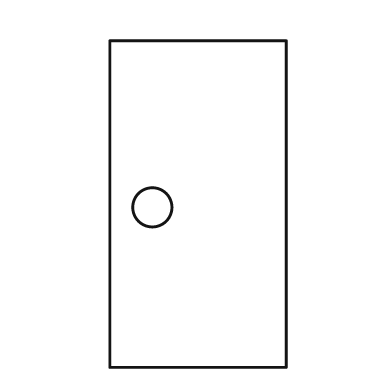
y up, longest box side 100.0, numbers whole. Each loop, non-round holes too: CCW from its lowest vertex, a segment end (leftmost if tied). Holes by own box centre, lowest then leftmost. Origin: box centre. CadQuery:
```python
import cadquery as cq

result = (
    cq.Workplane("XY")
    .moveTo(-27.0, -50.0)
    .lineTo(27.0, -50.0)
    .lineTo(27.0, 50.0)
    .lineTo(-27.0, 50.0)
    .close()
    .moveTo(-14.0, -1.0)
    .circle(6.0)
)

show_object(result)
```